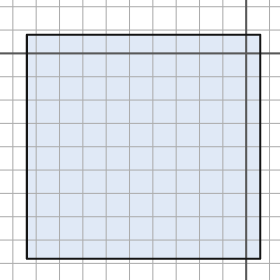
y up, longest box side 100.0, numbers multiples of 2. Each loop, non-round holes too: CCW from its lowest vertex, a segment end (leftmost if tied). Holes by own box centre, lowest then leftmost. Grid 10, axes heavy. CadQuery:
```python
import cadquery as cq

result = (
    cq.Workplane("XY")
    .moveTo(-94.0, -88.0)
    .lineTo(6.0, -88.0)
    .lineTo(6.0, 8.0)
    .lineTo(-94.0, 8.0)
    .close()
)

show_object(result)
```